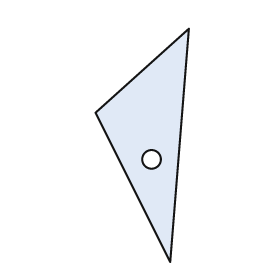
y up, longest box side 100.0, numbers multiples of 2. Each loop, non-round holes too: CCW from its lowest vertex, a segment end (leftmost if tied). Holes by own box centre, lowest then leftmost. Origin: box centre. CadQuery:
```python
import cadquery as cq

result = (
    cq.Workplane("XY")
    .moveTo(12.0, -50.0)
    .lineTo(20.0, 50.0)
    .lineTo(-20.0, 14.0)
    .close()
    .moveTo(4.0, -6.0)
    .circle(4.0)
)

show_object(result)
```